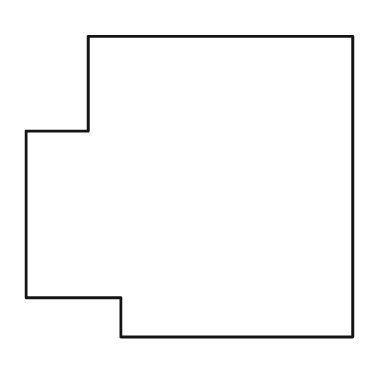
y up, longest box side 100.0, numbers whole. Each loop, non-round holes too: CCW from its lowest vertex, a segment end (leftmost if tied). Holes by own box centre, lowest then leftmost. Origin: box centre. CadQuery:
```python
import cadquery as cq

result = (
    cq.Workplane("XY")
    .moveTo(-21.0, -46.0)
    .lineTo(50.0, -46.0)
    .lineTo(50.0, 46.0)
    .lineTo(-31.0, 46.0)
    .lineTo(-31.0, 17.0)
    .lineTo(-50.0, 17.0)
    .lineTo(-50.0, -34.0)
    .lineTo(-21.0, -34.0)
    .close()
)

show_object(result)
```